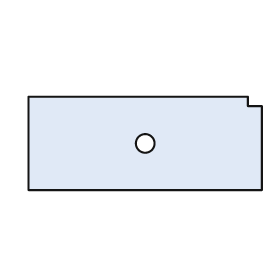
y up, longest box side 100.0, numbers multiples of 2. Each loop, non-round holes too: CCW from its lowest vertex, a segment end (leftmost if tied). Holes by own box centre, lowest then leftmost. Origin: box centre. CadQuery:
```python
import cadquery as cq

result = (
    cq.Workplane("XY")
    .moveTo(-50.0, -20.0)
    .lineTo(50.0, -20.0)
    .lineTo(50.0, 16.0)
    .lineTo(44.0, 16.0)
    .lineTo(44.0, 20.0)
    .lineTo(-50.0, 20.0)
    .close()
    .moveTo(0.0, 0.0)
    .circle(4.0)
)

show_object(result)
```